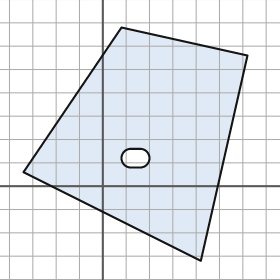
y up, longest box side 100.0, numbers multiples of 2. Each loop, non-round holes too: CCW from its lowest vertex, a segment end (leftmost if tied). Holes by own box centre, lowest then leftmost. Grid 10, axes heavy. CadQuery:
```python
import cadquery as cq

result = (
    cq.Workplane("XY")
    .moveTo(42.0, -32.0)
    .lineTo(62.0, 56.0)
    .lineTo(8.0, 68.0)
    .lineTo(-34.0, 6.0)
    .close()
    .moveTo(12.0, 8.0)
    .lineTo(16.0, 8.0)
    .threePointArc((20.0, 12.0), (16.0, 16.0))
    .lineTo(12.0, 16.0)
    .threePointArc((8.0, 12.0), (12.0, 8.0))
    .close()
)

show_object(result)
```